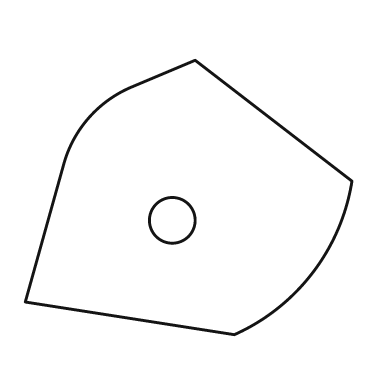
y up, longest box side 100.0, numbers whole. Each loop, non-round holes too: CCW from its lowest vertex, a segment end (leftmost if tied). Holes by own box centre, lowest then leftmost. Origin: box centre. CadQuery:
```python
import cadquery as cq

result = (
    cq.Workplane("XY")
    .moveTo(14.0, -42.0)
    .threePointArc((38.0, -23.0), (50.0, 5.0))
    .lineTo(2.0, 42.0)
    .lineTo(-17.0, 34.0)
    .threePointArc((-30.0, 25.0), (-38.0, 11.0))
    .lineTo(-50.0, -32.0)
    .close()
    .moveTo(-5.0, -7.0)
    .circle(7.0)
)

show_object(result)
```